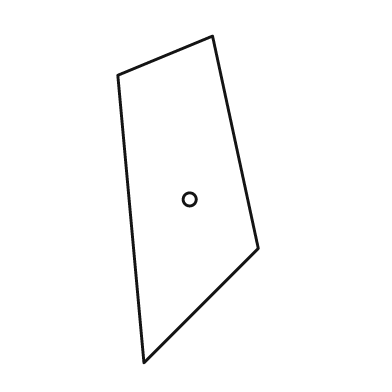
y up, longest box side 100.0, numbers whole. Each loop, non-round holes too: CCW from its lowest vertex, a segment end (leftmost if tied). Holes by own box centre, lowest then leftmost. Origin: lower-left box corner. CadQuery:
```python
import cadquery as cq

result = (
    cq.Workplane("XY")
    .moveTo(8.0, 0.0)
    .lineTo(43.0, 35.0)
    .lineTo(29.0, 100.0)
    .lineTo(0.0, 88.0)
    .close()
    .moveTo(22.0, 50.0)
    .circle(2.0)
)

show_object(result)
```